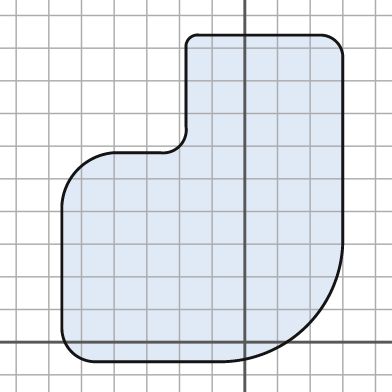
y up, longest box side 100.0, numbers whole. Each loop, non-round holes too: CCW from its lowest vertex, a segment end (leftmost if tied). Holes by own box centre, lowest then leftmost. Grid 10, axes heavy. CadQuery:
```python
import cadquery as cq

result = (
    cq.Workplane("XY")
    .moveTo(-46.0, -6.0)
    .lineTo(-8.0, -6.0)
    .threePointArc((19.0, 5.0), (30.0, 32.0))
    .lineTo(30.0, 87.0)
    .threePointArc((28.0, 92.0), (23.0, 94.0))
    .lineTo(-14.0, 94.0)
    .threePointArc((-17.0, 93.0), (-18.0, 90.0))
    .lineTo(-18.0, 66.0)
    .threePointArc((-20.0, 60.0), (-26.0, 58.0))
    .lineTo(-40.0, 58.0)
    .threePointArc((-51.0, 53.0), (-56.0, 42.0))
    .lineTo(-56.0, 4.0)
    .threePointArc((-53.0, -3.0), (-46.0, -6.0))
    .close()
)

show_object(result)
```